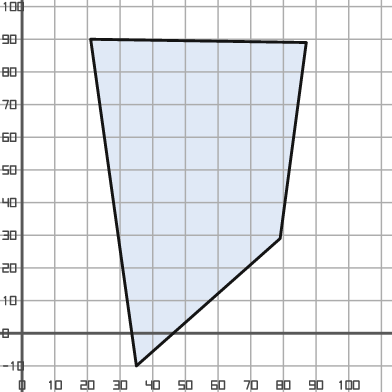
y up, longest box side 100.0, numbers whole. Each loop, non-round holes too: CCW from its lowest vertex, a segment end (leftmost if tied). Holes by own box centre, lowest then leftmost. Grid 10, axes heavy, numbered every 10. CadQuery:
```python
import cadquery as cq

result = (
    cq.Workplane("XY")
    .moveTo(35.0, -10.0)
    .lineTo(79.0, 29.0)
    .lineTo(87.0, 89.0)
    .lineTo(21.0, 90.0)
    .close()
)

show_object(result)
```